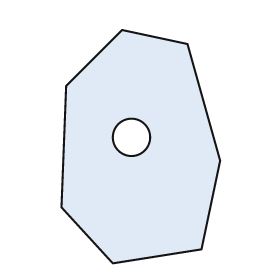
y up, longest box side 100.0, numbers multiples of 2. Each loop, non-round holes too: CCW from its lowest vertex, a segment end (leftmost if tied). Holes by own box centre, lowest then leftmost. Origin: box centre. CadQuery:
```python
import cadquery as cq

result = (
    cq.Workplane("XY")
    .moveTo(-12.0, -50.0)
    .lineTo(26.0, -44.0)
    .lineTo(34.0, -6.0)
    .lineTo(20.0, 44.0)
    .lineTo(-8.0, 50.0)
    .lineTo(-32.0, 26.0)
    .lineTo(-34.0, -26.0)
    .close()
    .moveTo(-4.0, 4.0)
    .circle(8.0)
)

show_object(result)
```